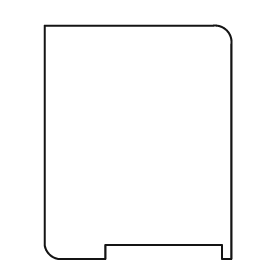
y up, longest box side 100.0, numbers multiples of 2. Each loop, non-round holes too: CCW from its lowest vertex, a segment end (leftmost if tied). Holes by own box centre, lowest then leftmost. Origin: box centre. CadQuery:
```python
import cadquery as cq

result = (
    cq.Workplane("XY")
    .moveTo(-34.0, -50.0)
    .lineTo(-14.0, -50.0)
    .lineTo(-14.0, -44.0)
    .lineTo(36.0, -44.0)
    .lineTo(36.0, -50.0)
    .lineTo(40.0, -50.0)
    .lineTo(40.0, 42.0)
    .threePointArc((38.0, 48.0), (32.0, 50.0))
    .lineTo(-40.0, 50.0)
    .lineTo(-40.0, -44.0)
    .threePointArc((-38.0, -48.0), (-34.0, -50.0))
    .close()
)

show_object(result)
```